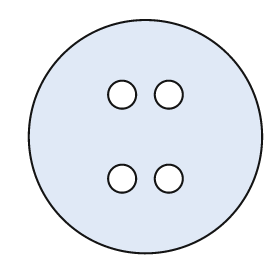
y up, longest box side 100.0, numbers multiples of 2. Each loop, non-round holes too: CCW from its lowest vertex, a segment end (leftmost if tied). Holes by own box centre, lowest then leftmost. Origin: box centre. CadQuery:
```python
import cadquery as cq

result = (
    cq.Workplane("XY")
    .moveTo(0.0, 0.0)
    .circle(50.0)
    .moveTo(-10.0, -18.0)
    .circle(6.0)
    .moveTo(10.0, -18.0)
    .circle(6.0)
    .moveTo(-10.0, 18.0)
    .circle(6.0)
    .moveTo(10.0, 18.0)
    .circle(6.0)
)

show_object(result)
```